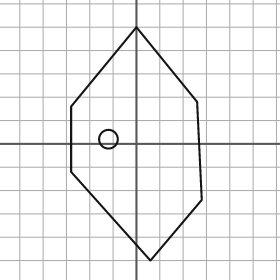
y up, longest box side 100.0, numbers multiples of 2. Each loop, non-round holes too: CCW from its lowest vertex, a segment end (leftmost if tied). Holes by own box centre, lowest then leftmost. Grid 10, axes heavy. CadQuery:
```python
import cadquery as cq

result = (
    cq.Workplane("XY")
    .moveTo(6.0, -50.0)
    .lineTo(28.0, -24.0)
    .lineTo(26.0, 18.0)
    .lineTo(0.0, 50.0)
    .lineTo(-28.0, 16.0)
    .lineTo(-28.0, -12.0)
    .close()
    .moveTo(-12.0, 2.0)
    .circle(4.0)
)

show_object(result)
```